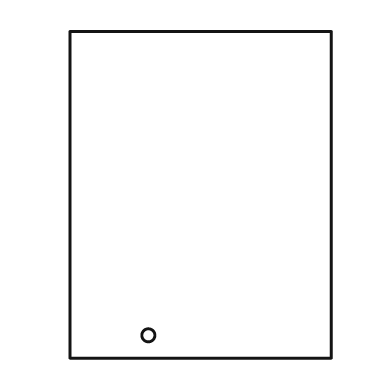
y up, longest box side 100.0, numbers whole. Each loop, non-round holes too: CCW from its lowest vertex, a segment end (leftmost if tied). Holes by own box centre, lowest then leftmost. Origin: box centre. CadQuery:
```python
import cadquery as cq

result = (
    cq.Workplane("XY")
    .moveTo(-40.0, -50.0)
    .lineTo(40.0, -50.0)
    .lineTo(40.0, 50.0)
    .lineTo(-40.0, 50.0)
    .close()
    .moveTo(-16.0, -43.0)
    .circle(2.0)
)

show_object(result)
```